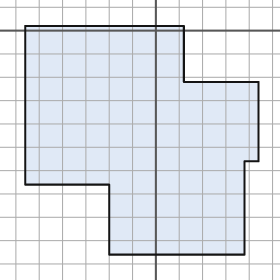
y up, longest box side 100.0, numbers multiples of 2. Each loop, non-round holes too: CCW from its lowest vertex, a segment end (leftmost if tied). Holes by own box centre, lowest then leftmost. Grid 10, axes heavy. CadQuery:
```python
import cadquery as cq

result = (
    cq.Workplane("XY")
    .moveTo(-20.0, -96.0)
    .lineTo(38.0, -96.0)
    .lineTo(38.0, -56.0)
    .lineTo(44.0, -56.0)
    .lineTo(44.0, -22.0)
    .lineTo(12.0, -22.0)
    .lineTo(12.0, 2.0)
    .lineTo(-56.0, 2.0)
    .lineTo(-56.0, -66.0)
    .lineTo(-20.0, -66.0)
    .close()
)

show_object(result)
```